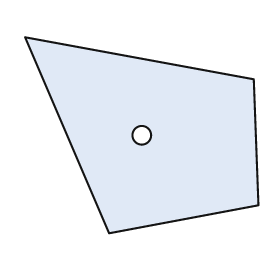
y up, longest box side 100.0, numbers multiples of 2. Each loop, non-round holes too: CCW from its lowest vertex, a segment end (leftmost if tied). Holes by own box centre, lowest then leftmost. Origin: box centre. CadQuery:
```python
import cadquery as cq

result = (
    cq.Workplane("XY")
    .moveTo(-14.0, -42.0)
    .lineTo(50.0, -30.0)
    .lineTo(48.0, 24.0)
    .lineTo(-50.0, 42.0)
    .close()
    .moveTo(0.0, 0.0)
    .circle(4.0)
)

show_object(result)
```